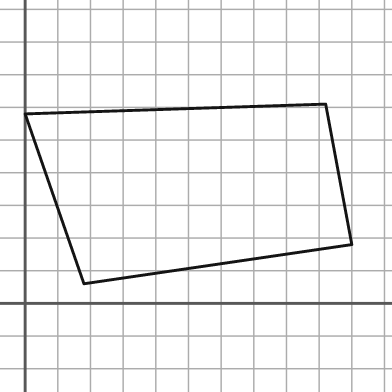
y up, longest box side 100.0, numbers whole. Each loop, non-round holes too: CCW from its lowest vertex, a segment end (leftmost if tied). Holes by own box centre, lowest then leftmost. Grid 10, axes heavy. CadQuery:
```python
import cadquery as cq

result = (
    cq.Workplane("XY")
    .moveTo(18.0, 6.0)
    .lineTo(100.0, 18.0)
    .lineTo(92.0, 61.0)
    .lineTo(0.0, 58.0)
    .close()
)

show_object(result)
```